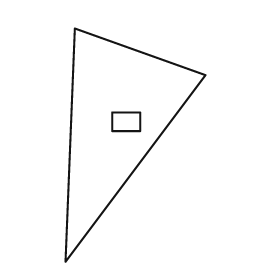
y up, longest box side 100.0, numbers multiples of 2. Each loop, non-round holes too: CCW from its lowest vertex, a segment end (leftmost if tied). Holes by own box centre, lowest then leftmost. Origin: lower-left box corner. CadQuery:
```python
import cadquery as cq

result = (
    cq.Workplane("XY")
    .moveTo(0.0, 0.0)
    .lineTo(60.0, 80.0)
    .lineTo(4.0, 100.0)
    .close()
    .moveTo(20.0, 56.0)
    .lineTo(32.0, 56.0)
    .lineTo(32.0, 64.0)
    .lineTo(20.0, 64.0)
    .close()
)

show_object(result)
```